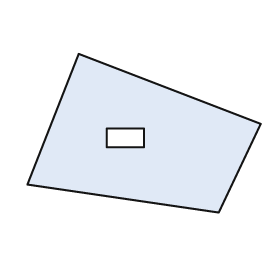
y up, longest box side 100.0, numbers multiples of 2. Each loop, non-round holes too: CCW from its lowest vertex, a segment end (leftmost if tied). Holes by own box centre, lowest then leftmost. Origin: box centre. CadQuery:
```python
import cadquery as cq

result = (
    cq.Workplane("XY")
    .moveTo(32.0, -34.0)
    .lineTo(50.0, 4.0)
    .lineTo(-28.0, 34.0)
    .lineTo(-50.0, -22.0)
    .close()
    .moveTo(-16.0, -6.0)
    .lineTo(0.0, -6.0)
    .lineTo(0.0, 2.0)
    .lineTo(-16.0, 2.0)
    .close()
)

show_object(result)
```